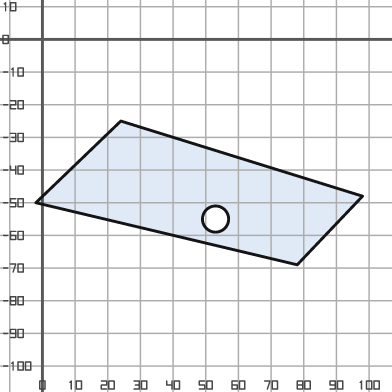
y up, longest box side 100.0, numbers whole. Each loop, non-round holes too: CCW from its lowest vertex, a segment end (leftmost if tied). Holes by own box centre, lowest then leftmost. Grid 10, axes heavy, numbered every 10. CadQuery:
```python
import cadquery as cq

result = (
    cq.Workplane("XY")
    .moveTo(78.0, -69.0)
    .lineTo(98.0, -48.0)
    .lineTo(24.0, -25.0)
    .lineTo(-2.0, -50.0)
    .close()
    .moveTo(53.0, -55.0)
    .circle(4.0)
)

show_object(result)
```